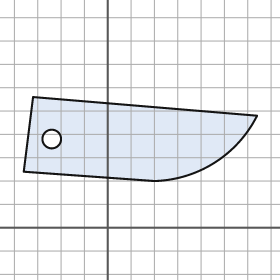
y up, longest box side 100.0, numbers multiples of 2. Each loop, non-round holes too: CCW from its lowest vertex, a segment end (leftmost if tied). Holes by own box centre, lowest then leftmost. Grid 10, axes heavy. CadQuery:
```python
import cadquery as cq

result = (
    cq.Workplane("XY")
    .moveTo(20.0, 20.0)
    .threePointArc((46.0, 28.0), (64.0, 48.0))
    .lineTo(-32.0, 56.0)
    .lineTo(-36.0, 24.0)
    .close()
    .moveTo(-24.0, 38.0)
    .circle(4.0)
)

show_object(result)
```